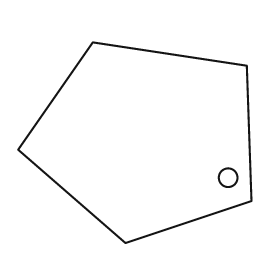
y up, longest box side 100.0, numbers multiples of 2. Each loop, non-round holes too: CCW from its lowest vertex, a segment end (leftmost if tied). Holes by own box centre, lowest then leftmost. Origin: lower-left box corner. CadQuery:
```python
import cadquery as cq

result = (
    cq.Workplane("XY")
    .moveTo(46.0, 0.0)
    .lineTo(100.0, 18.0)
    .lineTo(98.0, 76.0)
    .lineTo(32.0, 86.0)
    .lineTo(0.0, 40.0)
    .close()
    .moveTo(90.0, 28.0)
    .circle(4.0)
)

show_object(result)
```